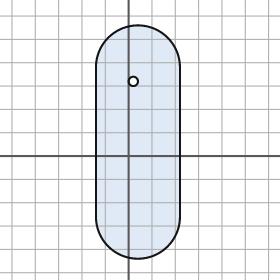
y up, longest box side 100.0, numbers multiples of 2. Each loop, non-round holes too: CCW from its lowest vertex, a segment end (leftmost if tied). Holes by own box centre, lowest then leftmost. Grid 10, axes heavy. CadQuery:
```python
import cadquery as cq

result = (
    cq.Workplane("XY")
    .moveTo(-14.0, -26.0)
    .threePointArc((4.0, -44.0), (22.0, -26.0))
    .lineTo(22.0, 38.0)
    .threePointArc((4.0, 56.0), (-14.0, 38.0))
    .close()
    .moveTo(2.0, 32.0)
    .circle(2.0)
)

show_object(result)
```